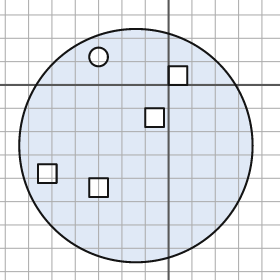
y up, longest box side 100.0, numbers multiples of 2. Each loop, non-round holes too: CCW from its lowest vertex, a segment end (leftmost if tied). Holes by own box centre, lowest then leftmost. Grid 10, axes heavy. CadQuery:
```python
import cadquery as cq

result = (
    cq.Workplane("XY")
    .moveTo(-14.0, -26.0)
    .circle(50.0)
    .moveTo(-34.0, -48.0)
    .lineTo(-26.0, -48.0)
    .lineTo(-26.0, -40.0)
    .lineTo(-34.0, -40.0)
    .close()
    .moveTo(-56.0, -42.0)
    .lineTo(-48.0, -42.0)
    .lineTo(-48.0, -34.0)
    .lineTo(-56.0, -34.0)
    .close()
    .moveTo(-10.0, -18.0)
    .lineTo(-2.0, -18.0)
    .lineTo(-2.0, -10.0)
    .lineTo(-10.0, -10.0)
    .close()
    .moveTo(0.0, 0.0)
    .lineTo(8.0, 0.0)
    .lineTo(8.0, 8.0)
    .lineTo(0.0, 8.0)
    .close()
    .moveTo(-30.0, 12.0)
    .circle(4.0)
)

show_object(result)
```